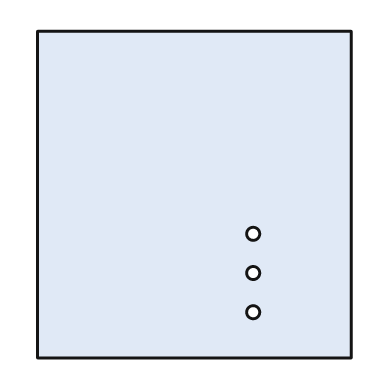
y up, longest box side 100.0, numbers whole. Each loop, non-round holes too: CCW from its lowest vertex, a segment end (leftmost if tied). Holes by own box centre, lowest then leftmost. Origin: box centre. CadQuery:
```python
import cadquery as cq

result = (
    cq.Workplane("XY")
    .moveTo(-48.0, -50.0)
    .lineTo(48.0, -50.0)
    .lineTo(48.0, 50.0)
    .lineTo(-48.0, 50.0)
    .close()
    .moveTo(18.0, -36.0)
    .circle(2.0)
    .moveTo(18.0, -24.0)
    .circle(2.0)
    .moveTo(18.0, -12.0)
    .circle(2.0)
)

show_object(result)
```